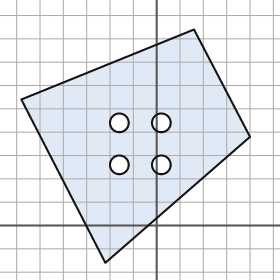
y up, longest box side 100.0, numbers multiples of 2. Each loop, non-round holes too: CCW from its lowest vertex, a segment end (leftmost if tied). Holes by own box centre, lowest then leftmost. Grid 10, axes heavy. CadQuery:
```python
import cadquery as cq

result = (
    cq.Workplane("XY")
    .moveTo(-22.0, -16.0)
    .lineTo(40.0, 38.0)
    .lineTo(16.0, 84.0)
    .lineTo(-58.0, 54.0)
    .close()
    .moveTo(-16.0, 26.0)
    .circle(4.0)
    .moveTo(2.0, 26.0)
    .circle(4.0)
    .moveTo(-16.0, 44.0)
    .circle(4.0)
    .moveTo(2.0, 44.0)
    .circle(4.0)
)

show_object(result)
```